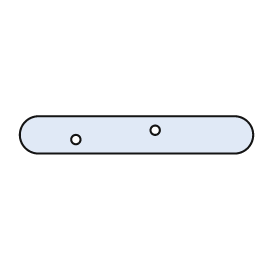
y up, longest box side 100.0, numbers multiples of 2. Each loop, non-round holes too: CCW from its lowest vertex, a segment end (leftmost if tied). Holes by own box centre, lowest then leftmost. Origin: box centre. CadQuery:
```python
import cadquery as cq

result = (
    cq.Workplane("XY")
    .moveTo(-42.0, -8.0)
    .lineTo(42.0, -8.0)
    .threePointArc((50.0, 0.0), (42.0, 8.0))
    .lineTo(-42.0, 8.0)
    .threePointArc((-50.0, 0.0), (-42.0, -8.0))
    .close()
    .moveTo(-26.0, -2.0)
    .circle(2.0)
    .moveTo(8.0, 2.0)
    .circle(2.0)
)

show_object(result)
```